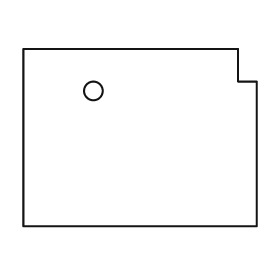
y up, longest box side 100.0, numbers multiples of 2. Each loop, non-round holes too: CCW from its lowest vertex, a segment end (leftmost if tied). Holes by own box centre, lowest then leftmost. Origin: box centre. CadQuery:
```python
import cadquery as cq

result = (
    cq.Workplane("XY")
    .moveTo(-50.0, -38.0)
    .lineTo(50.0, -38.0)
    .lineTo(50.0, 24.0)
    .lineTo(42.0, 24.0)
    .lineTo(42.0, 38.0)
    .lineTo(-50.0, 38.0)
    .close()
    .moveTo(-20.0, 20.0)
    .circle(4.0)
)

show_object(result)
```